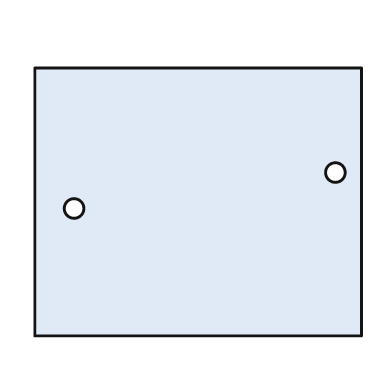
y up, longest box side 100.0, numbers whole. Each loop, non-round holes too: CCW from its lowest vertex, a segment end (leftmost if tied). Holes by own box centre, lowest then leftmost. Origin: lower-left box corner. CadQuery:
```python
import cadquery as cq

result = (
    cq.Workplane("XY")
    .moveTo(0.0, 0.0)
    .lineTo(100.0, 0.0)
    .lineTo(100.0, 82.0)
    .lineTo(0.0, 82.0)
    .close()
    .moveTo(12.0, 39.0)
    .circle(3.0)
    .moveTo(92.0, 50.0)
    .circle(3.0)
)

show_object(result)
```